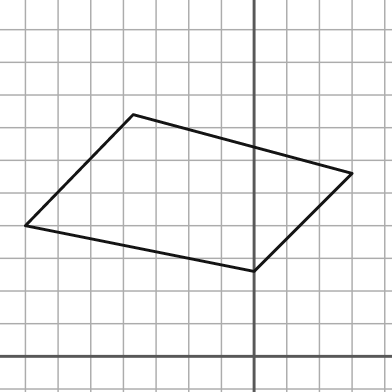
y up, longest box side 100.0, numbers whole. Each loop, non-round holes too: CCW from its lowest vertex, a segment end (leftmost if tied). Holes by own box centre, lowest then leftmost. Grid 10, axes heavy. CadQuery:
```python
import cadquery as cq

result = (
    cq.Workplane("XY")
    .moveTo(0.0, 26.0)
    .lineTo(30.0, 56.0)
    .lineTo(-37.0, 74.0)
    .lineTo(-70.0, 40.0)
    .close()
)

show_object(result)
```